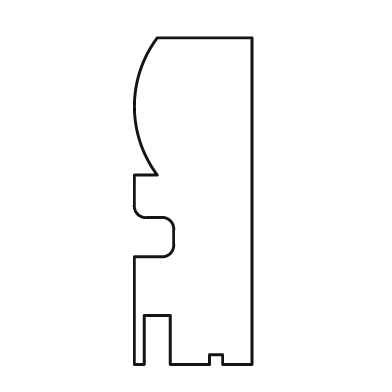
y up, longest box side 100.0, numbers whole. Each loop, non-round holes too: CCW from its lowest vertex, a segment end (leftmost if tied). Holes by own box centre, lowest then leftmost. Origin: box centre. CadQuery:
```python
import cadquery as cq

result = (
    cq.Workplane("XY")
    .moveTo(-18.0, -50.0)
    .lineTo(-15.0, -50.0)
    .lineTo(-15.0, -35.0)
    .lineTo(-7.0, -35.0)
    .lineTo(-7.0, -50.0)
    .lineTo(5.0, -50.0)
    .lineTo(5.0, -47.0)
    .lineTo(9.0, -47.0)
    .lineTo(9.0, -50.0)
    .lineTo(18.0, -50.0)
    .lineTo(18.0, 50.0)
    .lineTo(-11.0, 50.0)
    .threePointArc((-18.0, 29.0), (-11.0, 8.0))
    .lineTo(-18.0, 8.0)
    .lineTo(-18.0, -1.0)
    .threePointArc((-17.0, -4.0), (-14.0, -5.0))
    .lineTo(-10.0, -5.0)
    .threePointArc((-7.0, -6.0), (-6.0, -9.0))
    .lineTo(-6.0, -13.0)
    .threePointArc((-7.0, -16.0), (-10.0, -17.0))
    .lineTo(-18.0, -17.0)
    .close()
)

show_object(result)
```